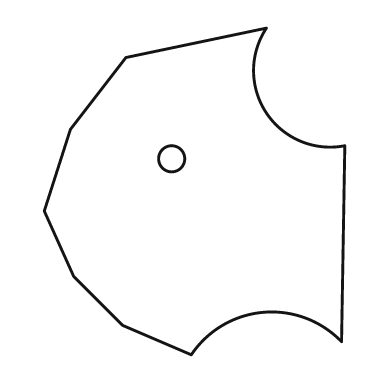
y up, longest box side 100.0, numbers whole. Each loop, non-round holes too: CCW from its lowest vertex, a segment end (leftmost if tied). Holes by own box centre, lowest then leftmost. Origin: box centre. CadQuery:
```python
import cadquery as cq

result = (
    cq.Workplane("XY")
    .moveTo(-1.0, -50.0)
    .threePointArc((21.0, -37.0), (45.0, -46.0))
    .lineTo(46.0, 14.0)
    .threePointArc((22.0, 24.0), (22.0, 50.0))
    .lineTo(-21.0, 41.0)
    .lineTo(-38.0, 19.0)
    .lineTo(-46.0, -6.0)
    .lineTo(-37.0, -26.0)
    .lineTo(-22.0, -41.0)
    .close()
    .moveTo(-7.0, 10.0)
    .circle(4.0)
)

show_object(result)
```